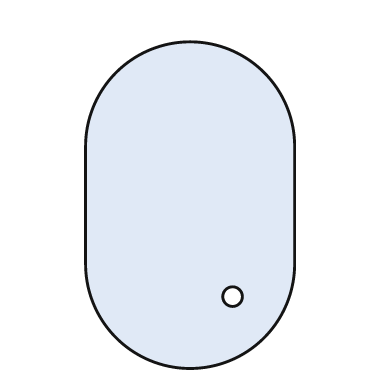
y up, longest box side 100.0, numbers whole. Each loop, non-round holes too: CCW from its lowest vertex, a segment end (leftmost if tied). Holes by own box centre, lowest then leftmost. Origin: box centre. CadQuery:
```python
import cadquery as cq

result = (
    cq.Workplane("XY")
    .moveTo(-32.0, -18.0)
    .threePointArc((0.0, -50.0), (32.0, -18.0))
    .lineTo(32.0, 18.0)
    .threePointArc((0.0, 50.0), (-32.0, 18.0))
    .close()
    .moveTo(13.0, -28.0)
    .circle(3.0)
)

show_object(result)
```